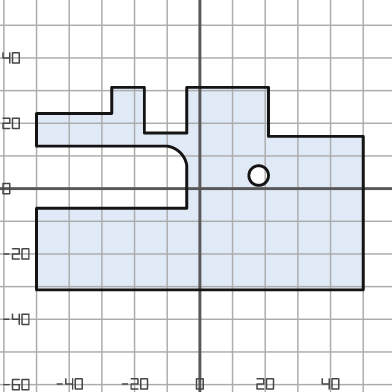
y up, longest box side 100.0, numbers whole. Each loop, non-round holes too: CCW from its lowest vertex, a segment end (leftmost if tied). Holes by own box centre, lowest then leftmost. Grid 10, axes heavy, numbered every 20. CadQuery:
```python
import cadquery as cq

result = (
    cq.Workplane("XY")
    .moveTo(-50.0, -31.0)
    .lineTo(50.0, -31.0)
    .lineTo(50.0, 16.0)
    .lineTo(21.0, 16.0)
    .lineTo(21.0, 31.0)
    .lineTo(-4.0, 31.0)
    .lineTo(-4.0, 17.0)
    .lineTo(-17.0, 17.0)
    .lineTo(-17.0, 31.0)
    .lineTo(-27.0, 31.0)
    .lineTo(-27.0, 23.0)
    .lineTo(-50.0, 23.0)
    .lineTo(-50.0, 13.0)
    .lineTo(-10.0, 13.0)
    .threePointArc((-6.0, 11.0), (-4.0, 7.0))
    .lineTo(-4.0, -6.0)
    .lineTo(-50.0, -6.0)
    .close()
    .moveTo(18.0, 4.0)
    .circle(3.0)
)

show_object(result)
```